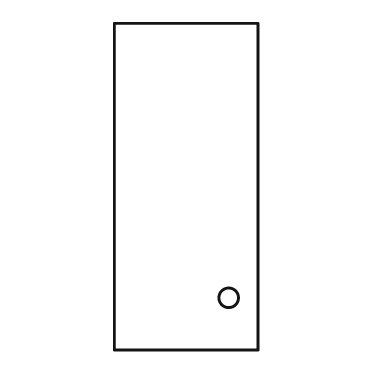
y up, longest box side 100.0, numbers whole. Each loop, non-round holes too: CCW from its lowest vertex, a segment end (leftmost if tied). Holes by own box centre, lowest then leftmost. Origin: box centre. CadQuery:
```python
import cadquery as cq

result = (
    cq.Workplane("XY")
    .moveTo(-22.0, -50.0)
    .lineTo(22.0, -50.0)
    .lineTo(22.0, 50.0)
    .lineTo(-22.0, 50.0)
    .close()
    .moveTo(13.0, -34.0)
    .circle(3.0)
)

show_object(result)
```